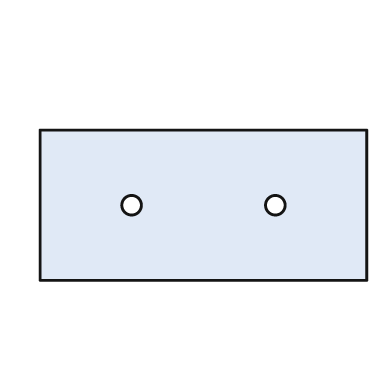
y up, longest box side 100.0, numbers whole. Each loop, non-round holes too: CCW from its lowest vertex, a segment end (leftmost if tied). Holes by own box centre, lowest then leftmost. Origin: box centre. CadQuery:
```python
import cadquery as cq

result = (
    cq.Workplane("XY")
    .moveTo(-50.0, -23.0)
    .lineTo(50.0, -23.0)
    .lineTo(50.0, 23.0)
    .lineTo(-50.0, 23.0)
    .close()
    .moveTo(-22.0, 0.0)
    .circle(3.0)
    .moveTo(22.0, 0.0)
    .circle(3.0)
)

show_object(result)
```